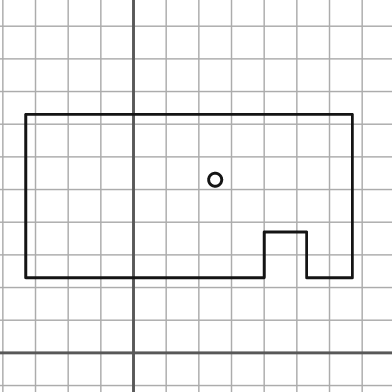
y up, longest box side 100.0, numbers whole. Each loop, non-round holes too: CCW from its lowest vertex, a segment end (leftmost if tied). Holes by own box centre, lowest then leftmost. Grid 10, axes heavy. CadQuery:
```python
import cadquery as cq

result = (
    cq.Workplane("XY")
    .moveTo(-33.0, 23.0)
    .lineTo(40.0, 23.0)
    .lineTo(40.0, 37.0)
    .lineTo(53.0, 37.0)
    .lineTo(53.0, 23.0)
    .lineTo(67.0, 23.0)
    .lineTo(67.0, 73.0)
    .lineTo(-33.0, 73.0)
    .close()
    .moveTo(25.0, 53.0)
    .circle(2.0)
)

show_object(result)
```